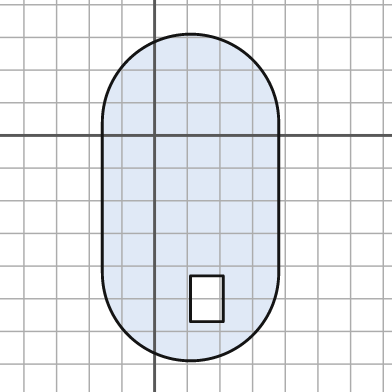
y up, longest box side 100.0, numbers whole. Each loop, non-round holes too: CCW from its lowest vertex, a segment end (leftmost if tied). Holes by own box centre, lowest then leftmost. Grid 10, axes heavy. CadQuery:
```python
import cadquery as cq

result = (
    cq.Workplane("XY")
    .moveTo(-16.0, -42.0)
    .threePointArc((11.0, -69.0), (38.0, -42.0))
    .lineTo(38.0, 4.0)
    .threePointArc((11.0, 31.0), (-16.0, 4.0))
    .close()
    .moveTo(11.0, -57.0)
    .lineTo(21.0, -57.0)
    .lineTo(21.0, -43.0)
    .lineTo(11.0, -43.0)
    .close()
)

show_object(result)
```